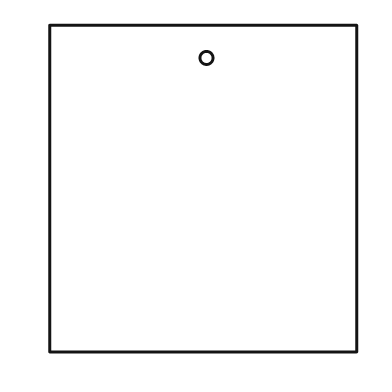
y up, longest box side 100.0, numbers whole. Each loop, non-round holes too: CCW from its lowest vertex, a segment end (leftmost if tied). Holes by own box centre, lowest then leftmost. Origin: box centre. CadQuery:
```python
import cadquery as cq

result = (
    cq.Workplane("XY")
    .moveTo(-47.0, -50.0)
    .lineTo(47.0, -50.0)
    .lineTo(47.0, 50.0)
    .lineTo(-47.0, 50.0)
    .close()
    .moveTo(1.0, 40.0)
    .circle(2.0)
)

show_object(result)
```